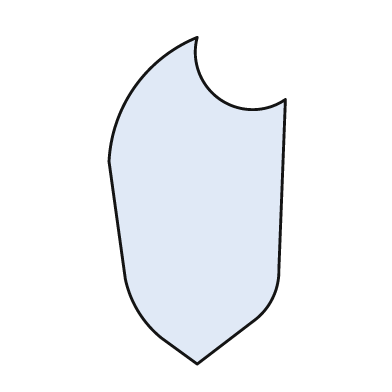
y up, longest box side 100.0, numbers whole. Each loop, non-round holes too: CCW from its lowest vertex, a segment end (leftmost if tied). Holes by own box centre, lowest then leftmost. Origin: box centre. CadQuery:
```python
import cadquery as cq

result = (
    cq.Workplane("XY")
    .moveTo(0.0, -50.0)
    .lineTo(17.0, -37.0)
    .threePointArc((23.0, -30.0), (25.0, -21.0))
    .lineTo(27.0, 31.0)
    .threePointArc((7.0, 31.0), (0.0, 50.0))
    .threePointArc((-19.0, 35.0), (-27.0, 12.0))
    .lineTo(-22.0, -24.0)
    .threePointArc((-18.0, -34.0), (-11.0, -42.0))
    .close()
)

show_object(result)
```